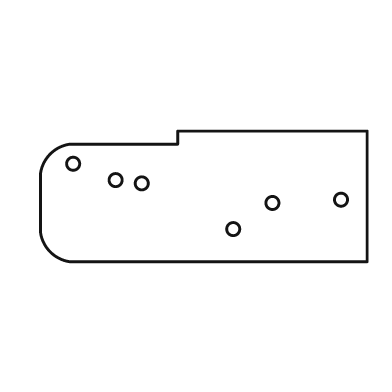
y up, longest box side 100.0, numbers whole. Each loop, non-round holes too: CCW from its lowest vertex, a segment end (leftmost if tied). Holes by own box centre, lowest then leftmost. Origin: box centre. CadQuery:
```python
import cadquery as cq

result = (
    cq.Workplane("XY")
    .moveTo(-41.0, -20.0)
    .lineTo(50.0, -20.0)
    .lineTo(50.0, 20.0)
    .lineTo(-8.0, 20.0)
    .lineTo(-8.0, 16.0)
    .lineTo(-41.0, 16.0)
    .threePointArc((-47.0, 13.0), (-50.0, 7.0))
    .lineTo(-50.0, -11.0)
    .threePointArc((-47.0, -17.0), (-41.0, -20.0))
    .close()
    .moveTo(9.0, -10.0)
    .circle(2.0)
    .moveTo(21.0, -2.0)
    .circle(2.0)
    .moveTo(42.0, -1.0)
    .circle(2.0)
    .moveTo(-19.0, 4.0)
    .circle(2.0)
    .moveTo(-27.0, 5.0)
    .circle(2.0)
    .moveTo(-40.0, 10.0)
    .circle(2.0)
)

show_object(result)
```